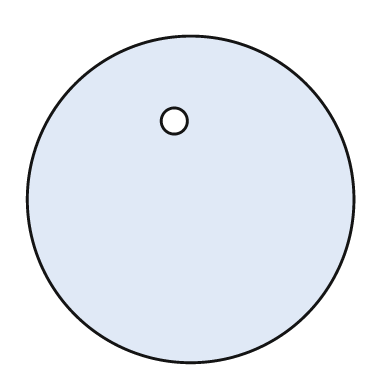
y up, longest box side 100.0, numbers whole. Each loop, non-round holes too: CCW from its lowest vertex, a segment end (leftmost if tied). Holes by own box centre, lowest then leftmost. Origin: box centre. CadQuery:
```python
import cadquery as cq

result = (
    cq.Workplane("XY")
    .moveTo(0.0, 0.0)
    .circle(50.0)
    .moveTo(-5.0, 24.0)
    .circle(4.0)
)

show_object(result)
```